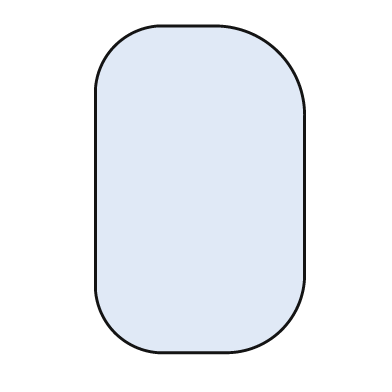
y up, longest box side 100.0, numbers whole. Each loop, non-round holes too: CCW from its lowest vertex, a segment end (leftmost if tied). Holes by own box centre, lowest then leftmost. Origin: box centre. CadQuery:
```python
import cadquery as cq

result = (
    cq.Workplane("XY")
    .moveTo(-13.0, -50.0)
    .lineTo(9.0, -50.0)
    .threePointArc((25.0, -43.0), (32.0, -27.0))
    .lineTo(32.0, 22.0)
    .threePointArc((24.0, 42.0), (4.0, 50.0))
    .lineTo(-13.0, 50.0)
    .threePointArc((-26.0, 44.0), (-32.0, 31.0))
    .lineTo(-32.0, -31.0)
    .threePointArc((-26.0, -44.0), (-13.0, -50.0))
    .close()
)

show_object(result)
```